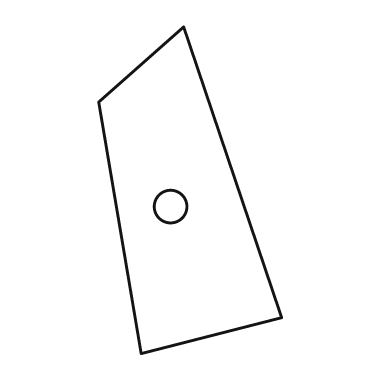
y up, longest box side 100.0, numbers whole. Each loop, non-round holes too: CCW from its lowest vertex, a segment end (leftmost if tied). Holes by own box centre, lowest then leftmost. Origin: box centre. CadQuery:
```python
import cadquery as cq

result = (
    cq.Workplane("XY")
    .moveTo(-15.0, -50.0)
    .lineTo(28.0, -39.0)
    .lineTo(-2.0, 50.0)
    .lineTo(-28.0, 27.0)
    .close()
    .moveTo(-6.0, -5.0)
    .circle(5.0)
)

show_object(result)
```